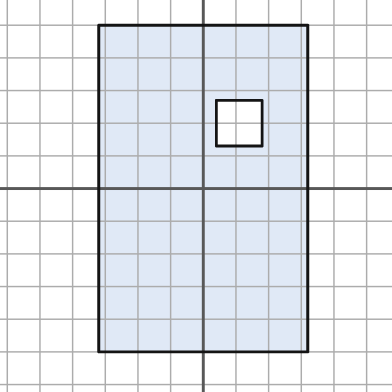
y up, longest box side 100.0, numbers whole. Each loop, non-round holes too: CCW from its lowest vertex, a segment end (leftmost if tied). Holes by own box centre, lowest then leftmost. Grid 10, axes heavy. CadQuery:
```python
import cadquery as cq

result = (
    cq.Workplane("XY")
    .moveTo(-32.0, -50.0)
    .lineTo(32.0, -50.0)
    .lineTo(32.0, 50.0)
    .lineTo(-32.0, 50.0)
    .close()
    .moveTo(4.0, 13.0)
    .lineTo(18.0, 13.0)
    .lineTo(18.0, 27.0)
    .lineTo(4.0, 27.0)
    .close()
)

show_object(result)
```